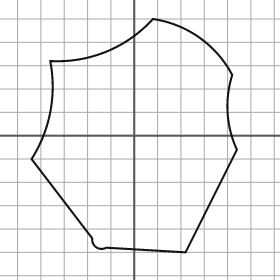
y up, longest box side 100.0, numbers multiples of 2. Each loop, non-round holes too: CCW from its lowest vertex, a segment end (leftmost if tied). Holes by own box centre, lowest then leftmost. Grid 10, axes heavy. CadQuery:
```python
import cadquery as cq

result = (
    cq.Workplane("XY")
    .moveTo(22.0, -50.0)
    .lineTo(44.0, -6.0)
    .threePointArc((40.0, 10.0), (42.0, 26.0))
    .threePointArc((28.0, 42.0), (8.0, 50.0))
    .threePointArc((-12.0, 36.0), (-36.0, 32.0))
    .threePointArc((-36.0, 10.0), (-44.0, -10.0))
    .lineTo(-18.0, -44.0)
    .threePointArc((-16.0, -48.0), (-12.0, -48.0))
    .close()
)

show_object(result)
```